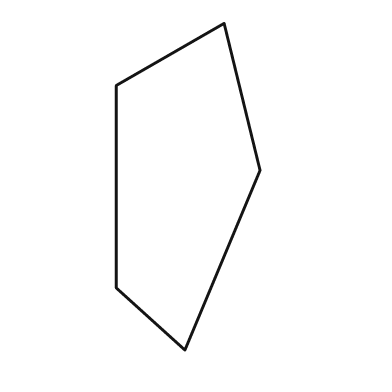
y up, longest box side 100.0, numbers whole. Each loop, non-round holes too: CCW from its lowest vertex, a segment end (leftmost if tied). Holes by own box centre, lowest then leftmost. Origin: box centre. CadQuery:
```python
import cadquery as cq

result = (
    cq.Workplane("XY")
    .moveTo(-1.0, -50.0)
    .lineTo(22.0, 5.0)
    .lineTo(11.0, 50.0)
    .lineTo(-22.0, 31.0)
    .lineTo(-22.0, -31.0)
    .close()
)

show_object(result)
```